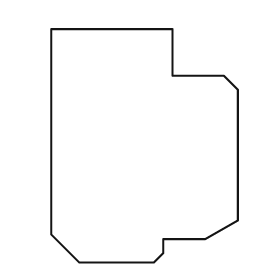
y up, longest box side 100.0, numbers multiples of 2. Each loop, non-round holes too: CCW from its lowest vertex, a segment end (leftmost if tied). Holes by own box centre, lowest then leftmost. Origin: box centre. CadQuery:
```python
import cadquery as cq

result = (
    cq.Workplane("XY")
    .moveTo(-28.0, -50.0)
    .lineTo(4.0, -50.0)
    .lineTo(8.0, -46.0)
    .lineTo(8.0, -40.0)
    .lineTo(26.0, -40.0)
    .lineTo(40.0, -32.0)
    .lineTo(40.0, 24.0)
    .lineTo(34.0, 30.0)
    .lineTo(12.0, 30.0)
    .lineTo(12.0, 50.0)
    .lineTo(-40.0, 50.0)
    .lineTo(-40.0, -38.0)
    .close()
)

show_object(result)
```